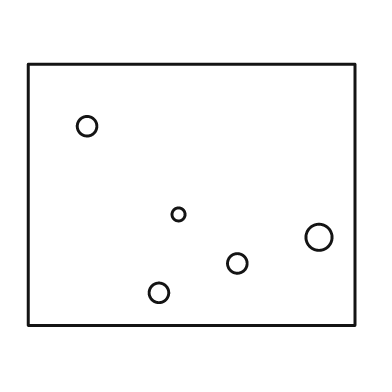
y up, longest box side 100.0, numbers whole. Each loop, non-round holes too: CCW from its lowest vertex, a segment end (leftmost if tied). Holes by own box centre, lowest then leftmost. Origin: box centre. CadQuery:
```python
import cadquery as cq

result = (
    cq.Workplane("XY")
    .moveTo(-50.0, -40.0)
    .lineTo(50.0, -40.0)
    .lineTo(50.0, 40.0)
    .lineTo(-50.0, 40.0)
    .close()
    .moveTo(-10.0, -30.0)
    .circle(3.0)
    .moveTo(14.0, -21.0)
    .circle(3.0)
    .moveTo(39.0, -13.0)
    .circle(4.0)
    .moveTo(-4.0, -6.0)
    .circle(2.0)
    .moveTo(-32.0, 21.0)
    .circle(3.0)
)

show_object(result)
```